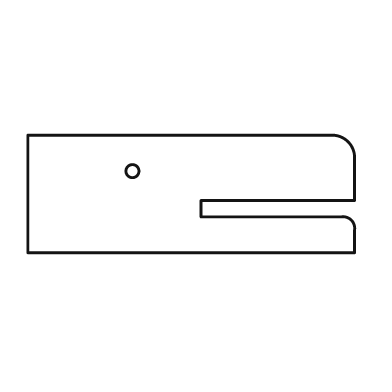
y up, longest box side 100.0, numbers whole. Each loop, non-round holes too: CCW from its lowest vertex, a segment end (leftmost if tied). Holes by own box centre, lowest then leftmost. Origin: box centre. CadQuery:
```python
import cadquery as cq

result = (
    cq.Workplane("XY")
    .moveTo(-50.0, -18.0)
    .lineTo(50.0, -18.0)
    .lineTo(50.0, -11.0)
    .threePointArc((49.0, -8.0), (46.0, -7.0))
    .lineTo(3.0, -7.0)
    .lineTo(3.0, -2.0)
    .lineTo(50.0, -2.0)
    .lineTo(50.0, 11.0)
    .threePointArc((48.0, 16.0), (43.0, 18.0))
    .lineTo(-50.0, 18.0)
    .close()
    .moveTo(-18.0, 7.0)
    .circle(2.0)
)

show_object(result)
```